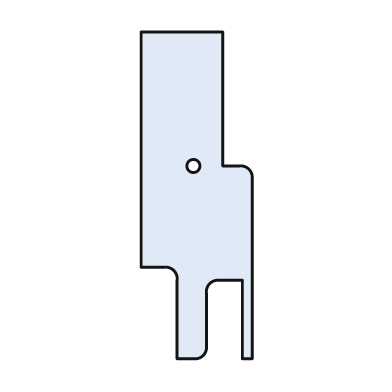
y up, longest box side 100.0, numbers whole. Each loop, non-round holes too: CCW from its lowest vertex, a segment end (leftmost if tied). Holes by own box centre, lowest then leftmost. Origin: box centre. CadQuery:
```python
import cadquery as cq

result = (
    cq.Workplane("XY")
    .moveTo(-6.0, -50.0)
    .lineTo(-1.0, -50.0)
    .threePointArc((2.0, -49.0), (3.0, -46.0))
    .lineTo(3.0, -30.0)
    .threePointArc((4.0, -27.0), (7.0, -26.0))
    .lineTo(14.0, -26.0)
    .lineTo(14.0, -50.0)
    .lineTo(17.0, -50.0)
    .lineTo(17.0, 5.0)
    .threePointArc((16.0, 8.0), (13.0, 9.0))
    .lineTo(8.0, 9.0)
    .lineTo(8.0, 50.0)
    .lineTo(-17.0, 50.0)
    .lineTo(-17.0, -22.0)
    .lineTo(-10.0, -22.0)
    .threePointArc((-7.0, -23.0), (-6.0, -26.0))
    .close()
    .moveTo(-1.0, 9.0)
    .circle(2.0)
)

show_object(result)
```